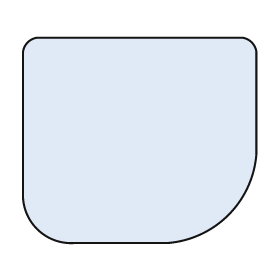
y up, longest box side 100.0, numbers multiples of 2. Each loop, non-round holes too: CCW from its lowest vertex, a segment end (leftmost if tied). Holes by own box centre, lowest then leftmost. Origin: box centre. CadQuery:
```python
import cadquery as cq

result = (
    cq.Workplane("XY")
    .moveTo(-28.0, -44.0)
    .lineTo(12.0, -44.0)
    .threePointArc((38.0, -32.0), (50.0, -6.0))
    .lineTo(50.0, 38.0)
    .threePointArc((48.0, 42.0), (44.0, 44.0))
    .lineTo(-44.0, 44.0)
    .threePointArc((-48.0, 42.0), (-50.0, 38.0))
    .lineTo(-50.0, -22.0)
    .threePointArc((-44.0, -38.0), (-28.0, -44.0))
    .close()
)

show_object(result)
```